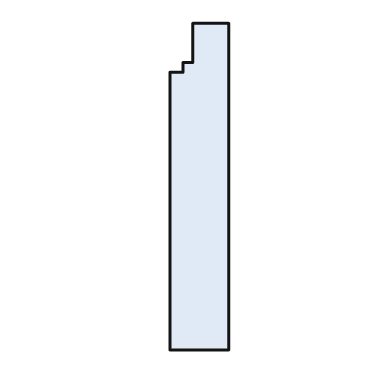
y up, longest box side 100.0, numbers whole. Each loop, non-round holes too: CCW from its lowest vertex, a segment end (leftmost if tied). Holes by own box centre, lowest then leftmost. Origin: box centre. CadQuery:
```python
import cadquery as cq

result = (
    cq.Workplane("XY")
    .moveTo(-9.0, -50.0)
    .lineTo(9.0, -50.0)
    .lineTo(9.0, 50.0)
    .lineTo(-2.0, 50.0)
    .lineTo(-2.0, 38.0)
    .lineTo(-5.0, 38.0)
    .lineTo(-5.0, 35.0)
    .lineTo(-9.0, 35.0)
    .close()
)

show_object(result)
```